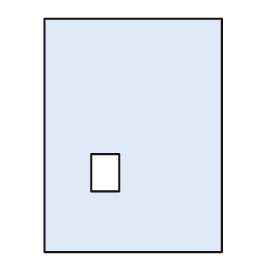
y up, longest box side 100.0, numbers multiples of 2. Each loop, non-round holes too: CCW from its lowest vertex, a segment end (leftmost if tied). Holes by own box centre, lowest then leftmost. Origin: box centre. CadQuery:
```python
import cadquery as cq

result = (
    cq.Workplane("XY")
    .moveTo(-38.0, -50.0)
    .lineTo(38.0, -50.0)
    .lineTo(38.0, 50.0)
    .lineTo(-38.0, 50.0)
    .close()
    .moveTo(-18.0, -24.0)
    .lineTo(-6.0, -24.0)
    .lineTo(-6.0, -8.0)
    .lineTo(-18.0, -8.0)
    .close()
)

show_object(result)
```